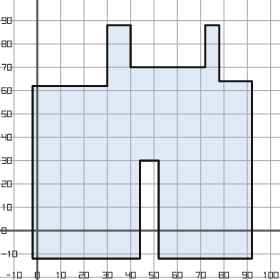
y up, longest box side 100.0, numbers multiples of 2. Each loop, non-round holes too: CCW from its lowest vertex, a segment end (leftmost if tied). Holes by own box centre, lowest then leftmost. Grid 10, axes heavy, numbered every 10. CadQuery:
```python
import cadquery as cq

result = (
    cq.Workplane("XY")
    .moveTo(-2.0, -12.0)
    .lineTo(44.0, -12.0)
    .lineTo(44.0, 30.0)
    .lineTo(52.0, 30.0)
    .lineTo(52.0, -12.0)
    .lineTo(92.0, -12.0)
    .lineTo(92.0, 64.0)
    .lineTo(78.0, 64.0)
    .lineTo(78.0, 88.0)
    .lineTo(72.0, 88.0)
    .lineTo(72.0, 70.0)
    .lineTo(40.0, 70.0)
    .lineTo(40.0, 88.0)
    .lineTo(30.0, 88.0)
    .lineTo(30.0, 62.0)
    .lineTo(-2.0, 62.0)
    .close()
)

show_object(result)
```